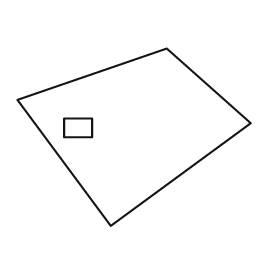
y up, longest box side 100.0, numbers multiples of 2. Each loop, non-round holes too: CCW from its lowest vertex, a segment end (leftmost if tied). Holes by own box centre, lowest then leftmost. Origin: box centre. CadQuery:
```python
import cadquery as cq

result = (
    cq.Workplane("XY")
    .moveTo(-10.0, -38.0)
    .lineTo(50.0, 6.0)
    .lineTo(14.0, 38.0)
    .lineTo(-50.0, 16.0)
    .close()
    .moveTo(-30.0, 0.0)
    .lineTo(-18.0, 0.0)
    .lineTo(-18.0, 8.0)
    .lineTo(-30.0, 8.0)
    .close()
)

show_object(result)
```